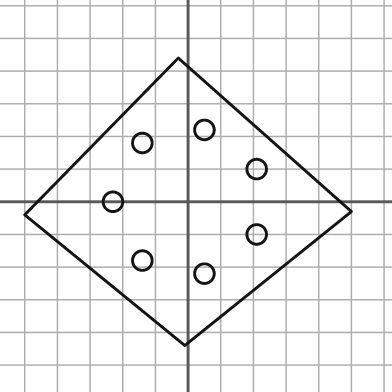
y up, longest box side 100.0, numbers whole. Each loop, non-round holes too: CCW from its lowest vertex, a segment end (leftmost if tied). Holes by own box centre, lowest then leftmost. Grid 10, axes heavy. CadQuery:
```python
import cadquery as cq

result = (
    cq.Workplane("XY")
    .moveTo(-1.0, -44.0)
    .lineTo(50.0, -3.0)
    .lineTo(-3.0, 44.0)
    .lineTo(-50.0, -4.0)
    .close()
    .moveTo(5.0, -22.0)
    .circle(3.0)
    .moveTo(-14.0, -18.0)
    .circle(3.0)
    .moveTo(21.0, -10.0)
    .circle(3.0)
    .moveTo(-23.0, 0.0)
    .circle(3.0)
    .moveTo(21.0, 10.0)
    .circle(3.0)
    .moveTo(-14.0, 18.0)
    .circle(3.0)
    .moveTo(5.0, 22.0)
    .circle(3.0)
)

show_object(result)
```